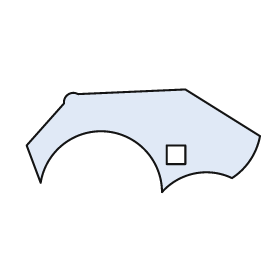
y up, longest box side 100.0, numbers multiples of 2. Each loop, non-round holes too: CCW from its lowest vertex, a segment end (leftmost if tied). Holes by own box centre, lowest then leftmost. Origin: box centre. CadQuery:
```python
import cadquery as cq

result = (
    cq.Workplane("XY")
    .moveTo(8.0, -22.0)
    .threePointArc((22.0, -14.0), (38.0, -16.0))
    .threePointArc((46.0, -8.0), (50.0, 2.0))
    .lineTo(18.0, 22.0)
    .lineTo(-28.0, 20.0)
    .threePointArc((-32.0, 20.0), (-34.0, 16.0))
    .lineTo(-50.0, -2.0)
    .lineTo(-44.0, -18.0)
    .threePointArc((-16.0, 4.0), (8.0, -22.0))
    .close()
    .moveTo(10.0, -10.0)
    .lineTo(18.0, -10.0)
    .lineTo(18.0, -2.0)
    .lineTo(10.0, -2.0)
    .close()
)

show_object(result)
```